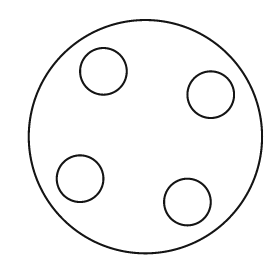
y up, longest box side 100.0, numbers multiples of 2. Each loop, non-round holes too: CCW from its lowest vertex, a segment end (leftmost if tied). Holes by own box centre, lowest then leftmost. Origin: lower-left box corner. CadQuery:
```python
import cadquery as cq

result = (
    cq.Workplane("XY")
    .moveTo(50.0, 50.0)
    .circle(50.0)
    .moveTo(68.0, 22.0)
    .circle(10.0)
    .moveTo(22.0, 32.0)
    .circle(10.0)
    .moveTo(78.0, 68.0)
    .circle(10.0)
    .moveTo(32.0, 78.0)
    .circle(10.0)
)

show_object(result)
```